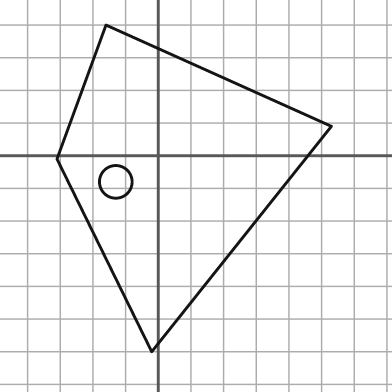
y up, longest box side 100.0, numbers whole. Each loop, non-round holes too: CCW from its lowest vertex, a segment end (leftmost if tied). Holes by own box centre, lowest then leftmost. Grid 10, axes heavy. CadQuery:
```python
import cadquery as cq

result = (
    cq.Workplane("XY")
    .moveTo(-2.0, -60.0)
    .lineTo(53.0, 9.0)
    .lineTo(-16.0, 40.0)
    .lineTo(-31.0, -1.0)
    .close()
    .moveTo(-13.0, -8.0)
    .circle(5.0)
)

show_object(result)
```